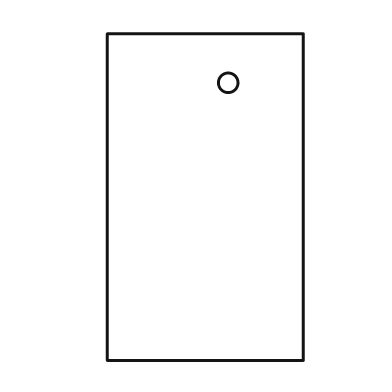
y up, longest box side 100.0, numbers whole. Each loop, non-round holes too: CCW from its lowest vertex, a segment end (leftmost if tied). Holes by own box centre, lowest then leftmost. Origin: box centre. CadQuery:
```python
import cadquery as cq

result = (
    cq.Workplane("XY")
    .moveTo(-30.0, -50.0)
    .lineTo(30.0, -50.0)
    .lineTo(30.0, 50.0)
    .lineTo(-30.0, 50.0)
    .close()
    .moveTo(7.0, 35.0)
    .circle(3.0)
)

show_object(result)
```